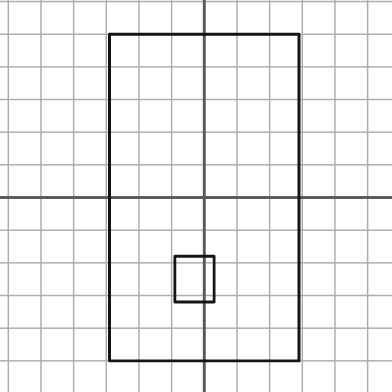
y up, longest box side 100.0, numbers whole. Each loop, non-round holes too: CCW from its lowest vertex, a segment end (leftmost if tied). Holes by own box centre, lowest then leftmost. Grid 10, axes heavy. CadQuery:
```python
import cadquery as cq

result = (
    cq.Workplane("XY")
    .moveTo(-29.0, -50.0)
    .lineTo(29.0, -50.0)
    .lineTo(29.0, 50.0)
    .lineTo(-29.0, 50.0)
    .close()
    .moveTo(-9.0, -32.0)
    .lineTo(3.0, -32.0)
    .lineTo(3.0, -18.0)
    .lineTo(-9.0, -18.0)
    .close()
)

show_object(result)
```